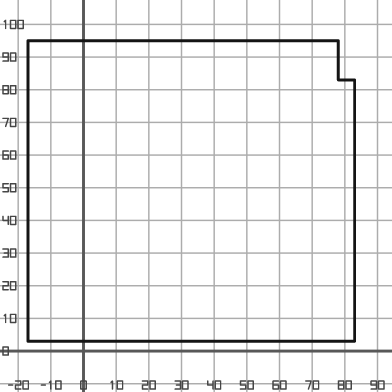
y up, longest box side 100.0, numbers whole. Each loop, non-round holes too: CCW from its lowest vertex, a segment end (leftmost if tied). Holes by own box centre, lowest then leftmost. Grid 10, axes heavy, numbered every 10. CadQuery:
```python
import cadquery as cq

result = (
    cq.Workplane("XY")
    .moveTo(-17.0, 3.0)
    .lineTo(83.0, 3.0)
    .lineTo(83.0, 83.0)
    .lineTo(78.0, 83.0)
    .lineTo(78.0, 95.0)
    .lineTo(-17.0, 95.0)
    .close()
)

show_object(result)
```